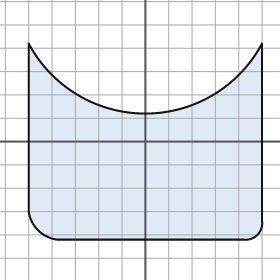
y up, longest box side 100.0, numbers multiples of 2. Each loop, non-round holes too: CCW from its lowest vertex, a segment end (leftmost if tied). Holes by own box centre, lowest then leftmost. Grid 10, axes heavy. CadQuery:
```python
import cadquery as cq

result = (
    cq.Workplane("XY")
    .moveTo(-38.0, -42.0)
    .lineTo(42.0, -42.0)
    .threePointArc((48.0, -40.0), (50.0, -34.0))
    .lineTo(50.0, 42.0)
    .threePointArc((0.0, 12.0), (-50.0, 42.0))
    .lineTo(-50.0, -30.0)
    .threePointArc((-46.0, -38.0), (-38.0, -42.0))
    .close()
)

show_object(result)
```